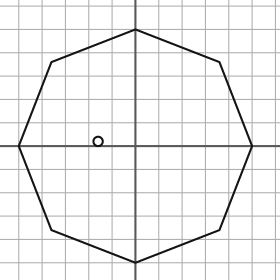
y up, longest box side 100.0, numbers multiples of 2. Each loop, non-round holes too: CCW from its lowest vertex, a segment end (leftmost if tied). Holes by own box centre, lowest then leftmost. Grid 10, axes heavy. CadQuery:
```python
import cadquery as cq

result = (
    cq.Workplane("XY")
    .moveTo(0.0, -50.0)
    .lineTo(36.0, -36.0)
    .lineTo(50.0, 0.0)
    .lineTo(36.0, 36.0)
    .lineTo(0.0, 50.0)
    .lineTo(-36.0, 36.0)
    .lineTo(-50.0, 0.0)
    .lineTo(-36.0, -36.0)
    .close()
    .moveTo(-16.0, 2.0)
    .circle(2.0)
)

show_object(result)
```